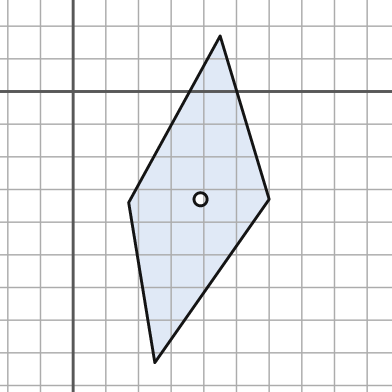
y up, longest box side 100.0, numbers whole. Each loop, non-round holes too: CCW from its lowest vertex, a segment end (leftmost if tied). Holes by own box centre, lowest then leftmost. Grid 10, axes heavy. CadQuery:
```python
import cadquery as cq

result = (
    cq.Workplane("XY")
    .moveTo(25.0, -83.0)
    .lineTo(60.0, -33.0)
    .lineTo(45.0, 17.0)
    .lineTo(17.0, -34.0)
    .close()
    .moveTo(39.0, -33.0)
    .circle(2.0)
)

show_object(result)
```